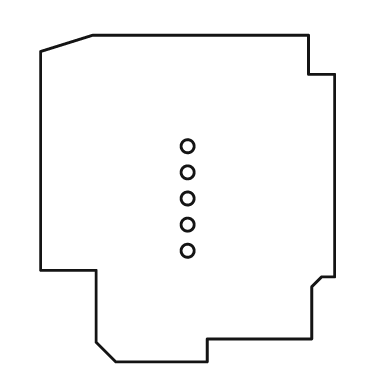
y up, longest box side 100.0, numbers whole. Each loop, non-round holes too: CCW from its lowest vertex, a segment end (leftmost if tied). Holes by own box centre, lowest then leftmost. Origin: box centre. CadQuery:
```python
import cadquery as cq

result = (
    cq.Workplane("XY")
    .moveTo(-22.0, -50.0)
    .lineTo(6.0, -50.0)
    .lineTo(6.0, -43.0)
    .lineTo(38.0, -43.0)
    .lineTo(38.0, -27.0)
    .lineTo(41.0, -24.0)
    .lineTo(45.0, -24.0)
    .lineTo(45.0, 38.0)
    .lineTo(37.0, 38.0)
    .lineTo(37.0, 50.0)
    .lineTo(-29.0, 50.0)
    .lineTo(-45.0, 45.0)
    .lineTo(-45.0, -22.0)
    .lineTo(-28.0, -22.0)
    .lineTo(-28.0, -44.0)
    .close()
    .moveTo(0.0, -16.0)
    .circle(2.0)
    .moveTo(0.0, -8.0)
    .circle(2.0)
    .moveTo(0.0, 0.0)
    .circle(2.0)
    .moveTo(0.0, 8.0)
    .circle(2.0)
    .moveTo(0.0, 16.0)
    .circle(2.0)
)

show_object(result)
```